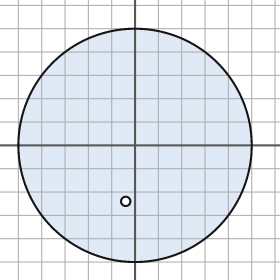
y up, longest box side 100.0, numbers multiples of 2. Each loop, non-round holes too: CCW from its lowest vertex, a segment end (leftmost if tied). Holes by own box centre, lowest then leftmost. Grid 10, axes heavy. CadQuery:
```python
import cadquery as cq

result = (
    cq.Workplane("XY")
    .moveTo(0.0, 0.0)
    .circle(50.0)
    .moveTo(-4.0, -24.0)
    .circle(2.0)
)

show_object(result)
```